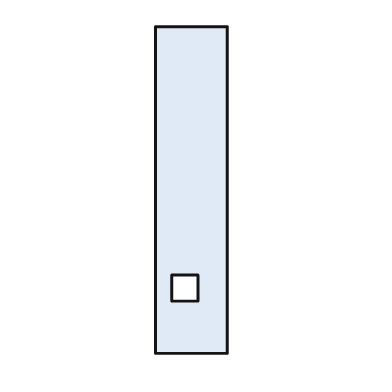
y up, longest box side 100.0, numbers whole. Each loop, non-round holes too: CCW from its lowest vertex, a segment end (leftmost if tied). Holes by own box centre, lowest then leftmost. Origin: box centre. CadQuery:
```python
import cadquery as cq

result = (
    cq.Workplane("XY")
    .moveTo(-11.0, -50.0)
    .lineTo(11.0, -50.0)
    .lineTo(11.0, 50.0)
    .lineTo(-11.0, 50.0)
    .close()
    .moveTo(-6.0, -34.0)
    .lineTo(2.0, -34.0)
    .lineTo(2.0, -26.0)
    .lineTo(-6.0, -26.0)
    .close()
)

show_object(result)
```